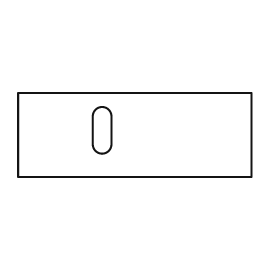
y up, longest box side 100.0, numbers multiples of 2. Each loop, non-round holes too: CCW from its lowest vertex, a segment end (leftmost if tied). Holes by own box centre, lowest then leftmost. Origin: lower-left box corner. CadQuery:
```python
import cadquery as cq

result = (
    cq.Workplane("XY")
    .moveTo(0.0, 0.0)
    .lineTo(100.0, 0.0)
    .lineTo(100.0, 36.0)
    .lineTo(0.0, 36.0)
    .close()
    .moveTo(32.0, 14.0)
    .threePointArc((36.0, 10.0), (40.0, 14.0))
    .lineTo(40.0, 26.0)
    .threePointArc((36.0, 30.0), (32.0, 26.0))
    .close()
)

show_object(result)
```